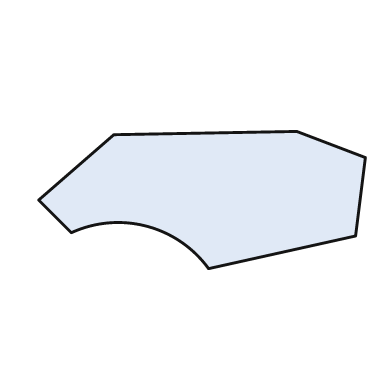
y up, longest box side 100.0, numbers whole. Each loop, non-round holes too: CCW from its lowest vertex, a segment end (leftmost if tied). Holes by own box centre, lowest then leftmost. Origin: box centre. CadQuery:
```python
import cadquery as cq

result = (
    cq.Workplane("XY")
    .moveTo(2.0, -21.0)
    .lineTo(47.0, -11.0)
    .lineTo(50.0, 13.0)
    .lineTo(29.0, 21.0)
    .lineTo(-27.0, 20.0)
    .lineTo(-50.0, 0.0)
    .lineTo(-40.0, -10.0)
    .threePointArc((-17.0, -8.0), (2.0, -21.0))
    .close()
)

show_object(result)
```